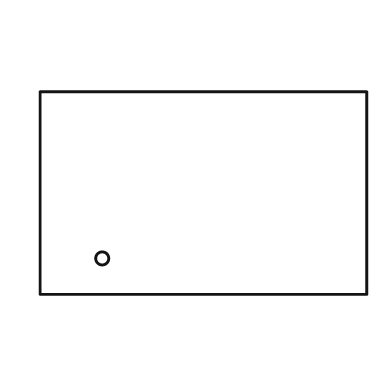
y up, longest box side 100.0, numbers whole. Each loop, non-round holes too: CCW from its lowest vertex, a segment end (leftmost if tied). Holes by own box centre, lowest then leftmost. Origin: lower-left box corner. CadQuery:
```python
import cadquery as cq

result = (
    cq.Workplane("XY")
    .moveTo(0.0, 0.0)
    .lineTo(100.0, 0.0)
    .lineTo(100.0, 62.0)
    .lineTo(0.0, 62.0)
    .close()
    .moveTo(19.0, 11.0)
    .circle(2.0)
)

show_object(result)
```